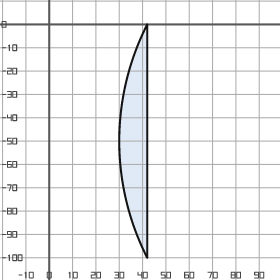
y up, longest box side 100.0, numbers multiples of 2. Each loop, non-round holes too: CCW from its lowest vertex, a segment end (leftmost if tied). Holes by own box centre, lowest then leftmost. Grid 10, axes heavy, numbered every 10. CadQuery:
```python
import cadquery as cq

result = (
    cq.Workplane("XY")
    .moveTo(42.0, -100.0)
    .lineTo(42.0, 0.0)
    .threePointArc((30.0, -50.0), (42.0, -100.0))
    .close()
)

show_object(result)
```